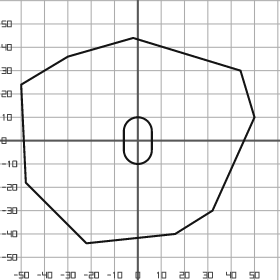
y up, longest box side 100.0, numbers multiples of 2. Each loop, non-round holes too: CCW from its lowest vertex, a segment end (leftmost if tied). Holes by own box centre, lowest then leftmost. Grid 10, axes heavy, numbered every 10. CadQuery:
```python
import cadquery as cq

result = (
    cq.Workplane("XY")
    .moveTo(-22.0, -44.0)
    .lineTo(16.0, -40.0)
    .lineTo(32.0, -30.0)
    .lineTo(50.0, 10.0)
    .lineTo(44.0, 30.0)
    .lineTo(-2.0, 44.0)
    .lineTo(-30.0, 36.0)
    .lineTo(-50.0, 24.0)
    .lineTo(-48.0, -18.0)
    .close()
    .moveTo(-6.0, -4.0)
    .threePointArc((0.0, -10.0), (6.0, -4.0))
    .lineTo(6.0, 4.0)
    .threePointArc((0.0, 10.0), (-6.0, 4.0))
    .close()
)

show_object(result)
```